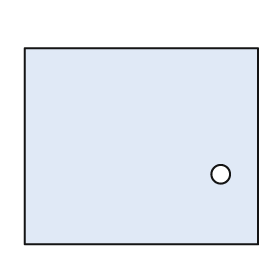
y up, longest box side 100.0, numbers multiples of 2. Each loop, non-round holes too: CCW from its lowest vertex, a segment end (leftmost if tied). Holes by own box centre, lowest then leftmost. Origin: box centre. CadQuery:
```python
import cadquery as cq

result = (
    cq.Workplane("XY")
    .moveTo(-50.0, -42.0)
    .lineTo(50.0, -42.0)
    .lineTo(50.0, 42.0)
    .lineTo(-50.0, 42.0)
    .close()
    .moveTo(34.0, -12.0)
    .circle(4.0)
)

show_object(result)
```